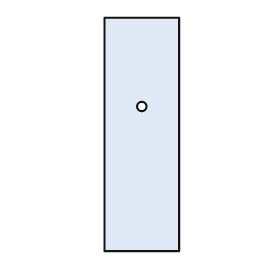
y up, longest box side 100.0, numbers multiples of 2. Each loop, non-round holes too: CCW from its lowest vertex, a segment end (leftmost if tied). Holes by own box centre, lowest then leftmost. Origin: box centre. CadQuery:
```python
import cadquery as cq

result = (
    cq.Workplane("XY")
    .moveTo(-16.0, -50.0)
    .lineTo(16.0, -50.0)
    .lineTo(16.0, 50.0)
    .lineTo(-16.0, 50.0)
    .close()
    .moveTo(0.0, 12.0)
    .circle(2.0)
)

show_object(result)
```